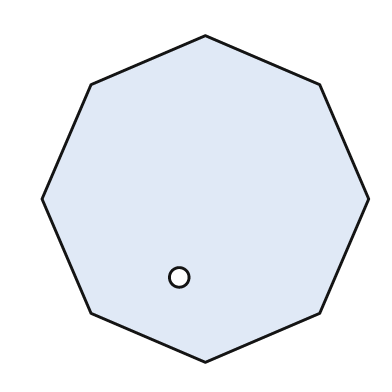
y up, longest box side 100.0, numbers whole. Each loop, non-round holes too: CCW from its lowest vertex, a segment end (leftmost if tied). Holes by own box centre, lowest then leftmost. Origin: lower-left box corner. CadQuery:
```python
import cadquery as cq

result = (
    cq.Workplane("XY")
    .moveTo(50.0, 0.0)
    .lineTo(85.0, 15.0)
    .lineTo(100.0, 50.0)
    .lineTo(85.0, 85.0)
    .lineTo(50.0, 100.0)
    .lineTo(15.0, 85.0)
    .lineTo(0.0, 50.0)
    .lineTo(15.0, 15.0)
    .close()
    .moveTo(42.0, 26.0)
    .circle(3.0)
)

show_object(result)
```